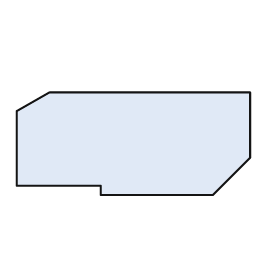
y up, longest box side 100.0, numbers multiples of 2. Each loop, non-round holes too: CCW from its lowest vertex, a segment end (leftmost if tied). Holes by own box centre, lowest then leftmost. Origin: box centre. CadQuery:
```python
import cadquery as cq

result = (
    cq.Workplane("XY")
    .moveTo(-14.0, -22.0)
    .lineTo(34.0, -22.0)
    .lineTo(50.0, -6.0)
    .lineTo(50.0, 22.0)
    .lineTo(-36.0, 22.0)
    .lineTo(-50.0, 14.0)
    .lineTo(-50.0, -18.0)
    .lineTo(-14.0, -18.0)
    .close()
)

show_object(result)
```